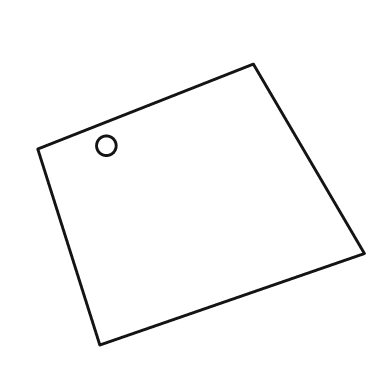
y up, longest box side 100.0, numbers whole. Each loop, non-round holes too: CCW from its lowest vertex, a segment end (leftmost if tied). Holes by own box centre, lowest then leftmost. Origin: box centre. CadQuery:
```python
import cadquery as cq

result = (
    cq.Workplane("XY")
    .moveTo(-31.0, -43.0)
    .lineTo(50.0, -15.0)
    .lineTo(16.0, 43.0)
    .lineTo(-50.0, 17.0)
    .close()
    .moveTo(-29.0, 18.0)
    .circle(3.0)
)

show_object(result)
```